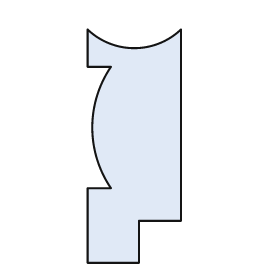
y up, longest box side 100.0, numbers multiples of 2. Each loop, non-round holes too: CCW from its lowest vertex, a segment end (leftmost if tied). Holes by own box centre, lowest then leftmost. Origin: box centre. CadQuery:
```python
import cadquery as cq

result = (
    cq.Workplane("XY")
    .moveTo(-20.0, -50.0)
    .lineTo(2.0, -50.0)
    .lineTo(2.0, -32.0)
    .lineTo(20.0, -32.0)
    .lineTo(20.0, 50.0)
    .threePointArc((0.0, 42.0), (-20.0, 50.0))
    .lineTo(-20.0, 34.0)
    .lineTo(-10.0, 34.0)
    .threePointArc((-18.0, 8.0), (-10.0, -18.0))
    .lineTo(-20.0, -18.0)
    .close()
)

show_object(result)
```